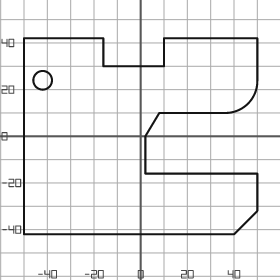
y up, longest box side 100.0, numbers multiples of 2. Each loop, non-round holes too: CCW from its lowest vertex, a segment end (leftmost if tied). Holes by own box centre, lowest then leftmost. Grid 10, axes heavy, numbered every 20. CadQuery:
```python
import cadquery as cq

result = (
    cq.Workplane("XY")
    .moveTo(-50.0, -42.0)
    .lineTo(40.0, -42.0)
    .lineTo(50.0, -32.0)
    .lineTo(50.0, -16.0)
    .lineTo(2.0, -16.0)
    .lineTo(2.0, 0.0)
    .lineTo(8.0, 10.0)
    .lineTo(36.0, 10.0)
    .threePointArc((46.0, 14.0), (50.0, 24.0))
    .lineTo(50.0, 42.0)
    .lineTo(10.0, 42.0)
    .lineTo(10.0, 30.0)
    .lineTo(-16.0, 30.0)
    .lineTo(-16.0, 42.0)
    .lineTo(-50.0, 42.0)
    .close()
    .moveTo(-42.0, 24.0)
    .circle(4.0)
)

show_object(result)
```